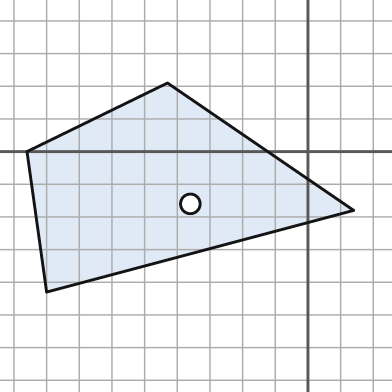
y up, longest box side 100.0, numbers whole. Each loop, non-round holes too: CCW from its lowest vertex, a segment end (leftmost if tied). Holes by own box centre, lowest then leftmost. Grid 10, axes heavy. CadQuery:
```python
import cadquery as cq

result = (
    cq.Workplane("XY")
    .moveTo(-80.0, -43.0)
    .lineTo(14.0, -18.0)
    .lineTo(-43.0, 21.0)
    .lineTo(-86.0, 0.0)
    .close()
    .moveTo(-36.0, -16.0)
    .circle(3.0)
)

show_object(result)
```